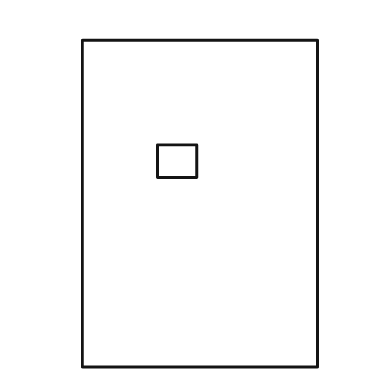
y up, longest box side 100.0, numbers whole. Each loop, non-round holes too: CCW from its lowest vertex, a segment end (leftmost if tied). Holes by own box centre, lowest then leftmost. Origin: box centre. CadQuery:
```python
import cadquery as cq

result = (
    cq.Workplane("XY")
    .moveTo(-36.0, -50.0)
    .lineTo(36.0, -50.0)
    .lineTo(36.0, 50.0)
    .lineTo(-36.0, 50.0)
    .close()
    .moveTo(-13.0, 8.0)
    .lineTo(-1.0, 8.0)
    .lineTo(-1.0, 18.0)
    .lineTo(-13.0, 18.0)
    .close()
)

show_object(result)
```